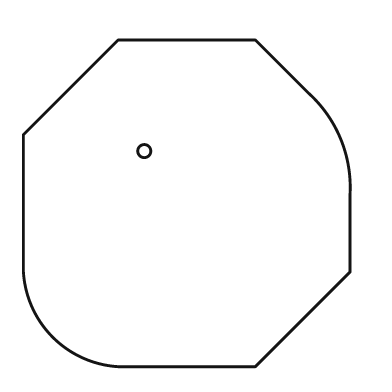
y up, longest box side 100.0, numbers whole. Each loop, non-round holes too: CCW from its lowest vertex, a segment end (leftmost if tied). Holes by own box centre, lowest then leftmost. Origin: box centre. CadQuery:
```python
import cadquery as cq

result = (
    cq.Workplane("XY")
    .moveTo(-21.0, -50.0)
    .lineTo(21.0, -50.0)
    .lineTo(50.0, -21.0)
    .lineTo(50.0, 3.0)
    .threePointArc((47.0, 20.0), (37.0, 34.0))
    .lineTo(21.0, 50.0)
    .lineTo(-21.0, 50.0)
    .lineTo(-50.0, 21.0)
    .lineTo(-50.0, -21.0)
    .threePointArc((-41.0, -41.0), (-21.0, -50.0))
    .close()
    .moveTo(-13.0, 16.0)
    .circle(2.0)
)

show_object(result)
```